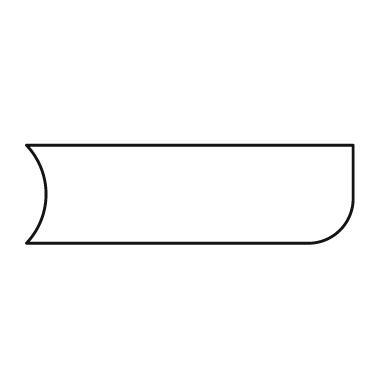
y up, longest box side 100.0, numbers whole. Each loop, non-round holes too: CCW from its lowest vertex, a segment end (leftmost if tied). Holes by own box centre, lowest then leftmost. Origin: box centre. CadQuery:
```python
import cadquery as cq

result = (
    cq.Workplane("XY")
    .moveTo(-50.0, -15.0)
    .lineTo(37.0, -15.0)
    .threePointArc((46.0, -11.0), (50.0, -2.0))
    .lineTo(50.0, 15.0)
    .lineTo(-50.0, 15.0)
    .threePointArc((-44.0, 0.0), (-50.0, -15.0))
    .close()
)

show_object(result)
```